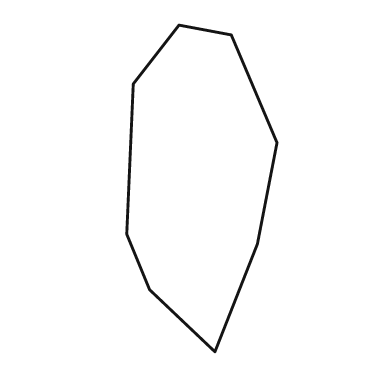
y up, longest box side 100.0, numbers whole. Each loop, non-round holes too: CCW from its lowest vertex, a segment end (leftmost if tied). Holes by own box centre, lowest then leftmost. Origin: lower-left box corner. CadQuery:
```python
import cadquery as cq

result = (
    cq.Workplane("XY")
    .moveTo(27.0, 0.0)
    .lineTo(40.0, 33.0)
    .lineTo(46.0, 64.0)
    .lineTo(32.0, 97.0)
    .lineTo(16.0, 100.0)
    .lineTo(2.0, 82.0)
    .lineTo(0.0, 36.0)
    .lineTo(7.0, 19.0)
    .close()
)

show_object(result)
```